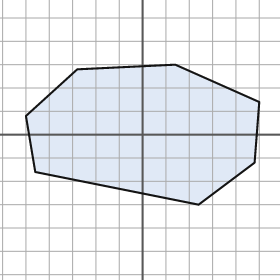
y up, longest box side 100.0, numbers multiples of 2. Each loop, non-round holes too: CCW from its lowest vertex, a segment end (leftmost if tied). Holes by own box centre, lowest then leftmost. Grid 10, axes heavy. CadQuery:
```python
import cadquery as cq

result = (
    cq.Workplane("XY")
    .moveTo(24.0, -30.0)
    .lineTo(48.0, -12.0)
    .lineTo(50.0, 14.0)
    .lineTo(14.0, 30.0)
    .lineTo(-28.0, 28.0)
    .lineTo(-50.0, 8.0)
    .lineTo(-46.0, -16.0)
    .close()
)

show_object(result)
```